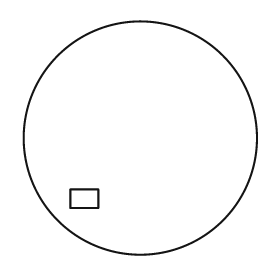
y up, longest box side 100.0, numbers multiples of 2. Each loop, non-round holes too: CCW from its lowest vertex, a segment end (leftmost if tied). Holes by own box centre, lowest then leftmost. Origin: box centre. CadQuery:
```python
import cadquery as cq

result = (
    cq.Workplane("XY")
    .moveTo(0.0, 0.0)
    .circle(50.0)
    .moveTo(-30.0, -30.0)
    .lineTo(-18.0, -30.0)
    .lineTo(-18.0, -22.0)
    .lineTo(-30.0, -22.0)
    .close()
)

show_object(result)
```